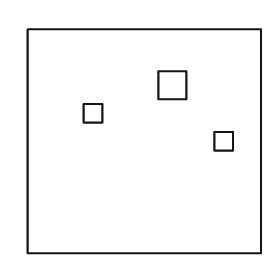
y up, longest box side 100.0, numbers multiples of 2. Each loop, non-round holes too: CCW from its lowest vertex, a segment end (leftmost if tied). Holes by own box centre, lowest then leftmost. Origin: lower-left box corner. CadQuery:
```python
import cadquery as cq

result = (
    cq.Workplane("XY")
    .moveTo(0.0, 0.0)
    .lineTo(100.0, 0.0)
    .lineTo(100.0, 96.0)
    .lineTo(0.0, 96.0)
    .close()
    .moveTo(80.0, 44.0)
    .lineTo(88.0, 44.0)
    .lineTo(88.0, 52.0)
    .lineTo(80.0, 52.0)
    .close()
    .moveTo(24.0, 56.0)
    .lineTo(32.0, 56.0)
    .lineTo(32.0, 64.0)
    .lineTo(24.0, 64.0)
    .close()
    .moveTo(56.0, 66.0)
    .lineTo(68.0, 66.0)
    .lineTo(68.0, 78.0)
    .lineTo(56.0, 78.0)
    .close()
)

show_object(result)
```